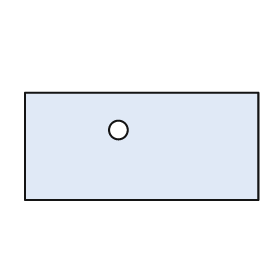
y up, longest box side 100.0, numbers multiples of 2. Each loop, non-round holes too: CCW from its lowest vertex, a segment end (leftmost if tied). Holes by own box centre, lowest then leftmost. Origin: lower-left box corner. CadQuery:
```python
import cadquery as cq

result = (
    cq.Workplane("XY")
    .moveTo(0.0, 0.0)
    .lineTo(100.0, 0.0)
    .lineTo(100.0, 46.0)
    .lineTo(0.0, 46.0)
    .close()
    .moveTo(40.0, 30.0)
    .circle(4.0)
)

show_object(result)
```